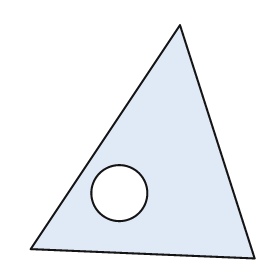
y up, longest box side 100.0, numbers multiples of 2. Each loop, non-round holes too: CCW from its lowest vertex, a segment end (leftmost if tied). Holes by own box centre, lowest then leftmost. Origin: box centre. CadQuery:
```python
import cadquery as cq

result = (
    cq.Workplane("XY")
    .moveTo(48.0, -50.0)
    .lineTo(16.0, 50.0)
    .lineTo(-48.0, -46.0)
    .close()
    .moveTo(-10.0, -22.0)
    .circle(12.0)
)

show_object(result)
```